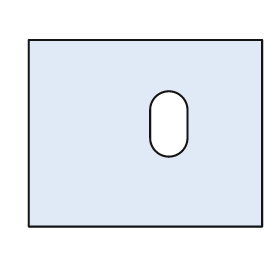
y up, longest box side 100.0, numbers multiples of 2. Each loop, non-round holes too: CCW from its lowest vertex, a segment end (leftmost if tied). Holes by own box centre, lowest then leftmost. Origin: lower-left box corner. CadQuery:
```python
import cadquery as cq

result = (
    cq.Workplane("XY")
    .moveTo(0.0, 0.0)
    .lineTo(100.0, 0.0)
    .lineTo(100.0, 80.0)
    .lineTo(0.0, 80.0)
    .close()
    .moveTo(52.0, 38.0)
    .threePointArc((60.0, 30.0), (68.0, 38.0))
    .lineTo(68.0, 50.0)
    .threePointArc((60.0, 58.0), (52.0, 50.0))
    .close()
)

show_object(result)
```